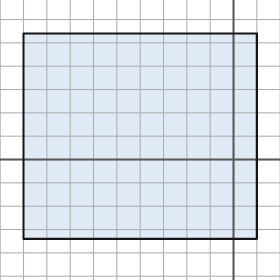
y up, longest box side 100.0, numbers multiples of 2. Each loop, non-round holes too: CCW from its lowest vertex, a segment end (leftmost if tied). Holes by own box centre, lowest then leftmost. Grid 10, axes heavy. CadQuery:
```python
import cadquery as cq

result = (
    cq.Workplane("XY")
    .moveTo(-90.0, -34.0)
    .lineTo(10.0, -34.0)
    .lineTo(10.0, 54.0)
    .lineTo(-90.0, 54.0)
    .close()
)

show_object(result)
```